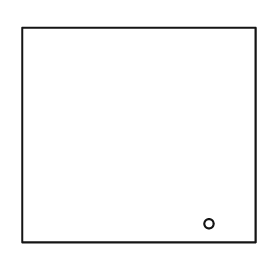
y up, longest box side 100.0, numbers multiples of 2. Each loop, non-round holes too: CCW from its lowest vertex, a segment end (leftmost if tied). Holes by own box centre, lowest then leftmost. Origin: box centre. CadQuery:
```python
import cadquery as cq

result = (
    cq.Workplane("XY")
    .moveTo(-50.0, -46.0)
    .lineTo(50.0, -46.0)
    .lineTo(50.0, 46.0)
    .lineTo(-50.0, 46.0)
    .close()
    .moveTo(30.0, -38.0)
    .circle(2.0)
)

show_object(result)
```